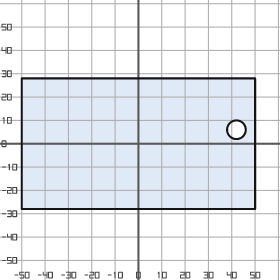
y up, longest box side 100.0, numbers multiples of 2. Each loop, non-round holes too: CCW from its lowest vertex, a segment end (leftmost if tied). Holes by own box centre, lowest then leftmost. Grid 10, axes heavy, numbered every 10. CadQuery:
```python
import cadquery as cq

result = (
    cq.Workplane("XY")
    .moveTo(-50.0, -28.0)
    .lineTo(50.0, -28.0)
    .lineTo(50.0, 28.0)
    .lineTo(-50.0, 28.0)
    .close()
    .moveTo(42.0, 6.0)
    .circle(4.0)
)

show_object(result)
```